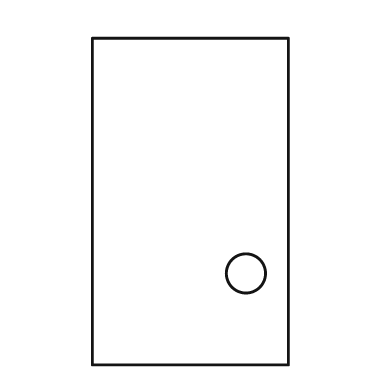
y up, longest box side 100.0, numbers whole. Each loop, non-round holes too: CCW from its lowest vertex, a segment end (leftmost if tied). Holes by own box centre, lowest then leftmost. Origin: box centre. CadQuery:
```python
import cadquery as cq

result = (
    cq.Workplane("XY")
    .moveTo(-30.0, -50.0)
    .lineTo(30.0, -50.0)
    .lineTo(30.0, 50.0)
    .lineTo(-30.0, 50.0)
    .close()
    .moveTo(17.0, -22.0)
    .circle(6.0)
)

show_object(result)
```